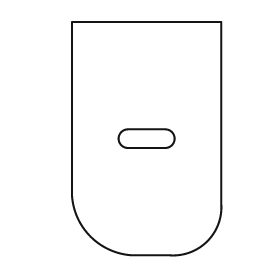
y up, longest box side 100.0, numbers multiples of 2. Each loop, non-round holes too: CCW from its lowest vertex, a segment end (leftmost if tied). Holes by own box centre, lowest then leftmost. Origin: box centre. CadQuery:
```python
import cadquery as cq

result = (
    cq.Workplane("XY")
    .moveTo(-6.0, -50.0)
    .lineTo(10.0, -50.0)
    .threePointArc((26.0, -44.0), (32.0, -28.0))
    .lineTo(32.0, 50.0)
    .lineTo(-32.0, 50.0)
    .lineTo(-32.0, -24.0)
    .threePointArc((-24.0, -42.0), (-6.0, -50.0))
    .close()
    .moveTo(-8.0, -4.0)
    .lineTo(8.0, -4.0)
    .threePointArc((12.0, 0.0), (8.0, 4.0))
    .lineTo(-8.0, 4.0)
    .threePointArc((-12.0, 0.0), (-8.0, -4.0))
    .close()
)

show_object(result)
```